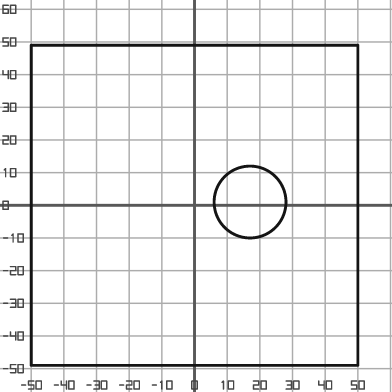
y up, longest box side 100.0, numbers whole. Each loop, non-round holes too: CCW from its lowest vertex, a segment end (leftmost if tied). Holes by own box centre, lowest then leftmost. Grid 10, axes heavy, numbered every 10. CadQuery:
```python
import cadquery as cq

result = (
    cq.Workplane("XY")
    .moveTo(-50.0, -49.0)
    .lineTo(50.0, -49.0)
    .lineTo(50.0, 49.0)
    .lineTo(-50.0, 49.0)
    .close()
    .moveTo(17.0, 1.0)
    .circle(11.0)
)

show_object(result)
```